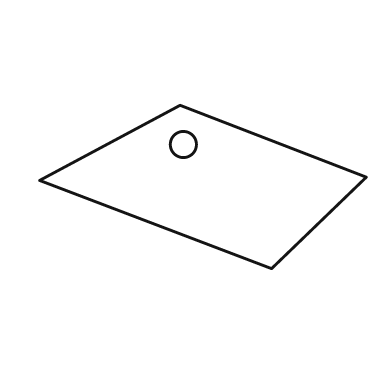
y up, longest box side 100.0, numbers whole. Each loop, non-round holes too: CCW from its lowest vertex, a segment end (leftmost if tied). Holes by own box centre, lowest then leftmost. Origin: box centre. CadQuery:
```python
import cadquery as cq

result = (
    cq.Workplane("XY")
    .moveTo(21.0, -25.0)
    .lineTo(50.0, 3.0)
    .lineTo(-7.0, 25.0)
    .lineTo(-50.0, 2.0)
    .close()
    .moveTo(-6.0, 13.0)
    .circle(4.0)
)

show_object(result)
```